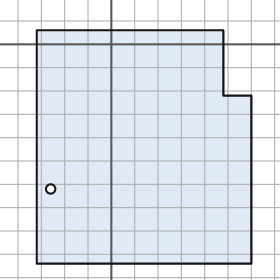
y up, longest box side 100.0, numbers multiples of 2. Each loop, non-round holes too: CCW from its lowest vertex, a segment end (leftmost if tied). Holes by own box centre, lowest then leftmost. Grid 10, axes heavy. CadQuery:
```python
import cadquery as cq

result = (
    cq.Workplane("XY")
    .moveTo(-32.0, -94.0)
    .lineTo(60.0, -94.0)
    .lineTo(60.0, -22.0)
    .lineTo(48.0, -22.0)
    .lineTo(48.0, 6.0)
    .lineTo(-32.0, 6.0)
    .close()
    .moveTo(-26.0, -62.0)
    .circle(2.0)
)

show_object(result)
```